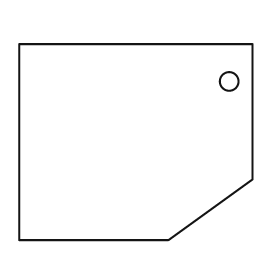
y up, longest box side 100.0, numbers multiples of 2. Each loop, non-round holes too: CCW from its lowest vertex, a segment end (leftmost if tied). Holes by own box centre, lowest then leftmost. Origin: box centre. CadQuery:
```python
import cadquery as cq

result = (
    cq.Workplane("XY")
    .moveTo(-50.0, -42.0)
    .lineTo(14.0, -42.0)
    .lineTo(50.0, -16.0)
    .lineTo(50.0, 42.0)
    .lineTo(-50.0, 42.0)
    .close()
    .moveTo(40.0, 26.0)
    .circle(4.0)
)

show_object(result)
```